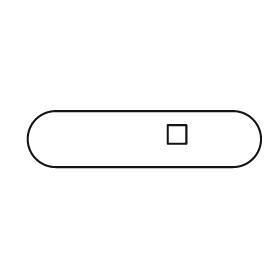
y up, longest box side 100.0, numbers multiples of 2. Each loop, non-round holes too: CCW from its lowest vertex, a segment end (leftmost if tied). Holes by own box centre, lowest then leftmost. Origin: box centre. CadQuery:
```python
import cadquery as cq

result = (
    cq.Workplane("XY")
    .moveTo(-38.0, -12.0)
    .lineTo(38.0, -12.0)
    .threePointArc((50.0, 0.0), (38.0, 12.0))
    .lineTo(-38.0, 12.0)
    .threePointArc((-50.0, 0.0), (-38.0, -12.0))
    .close()
    .moveTo(10.0, -2.0)
    .lineTo(18.0, -2.0)
    .lineTo(18.0, 6.0)
    .lineTo(10.0, 6.0)
    .close()
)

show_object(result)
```